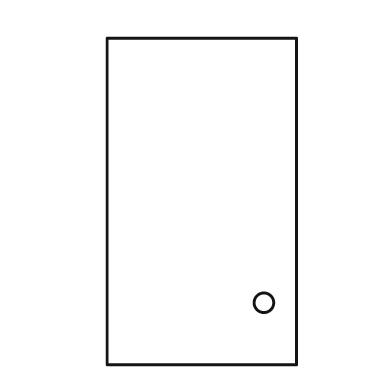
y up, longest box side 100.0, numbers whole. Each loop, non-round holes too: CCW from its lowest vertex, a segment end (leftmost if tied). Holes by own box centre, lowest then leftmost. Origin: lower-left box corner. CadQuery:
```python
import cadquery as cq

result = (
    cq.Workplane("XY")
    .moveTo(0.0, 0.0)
    .lineTo(58.0, 0.0)
    .lineTo(58.0, 100.0)
    .lineTo(0.0, 100.0)
    .close()
    .moveTo(48.0, 19.0)
    .circle(3.0)
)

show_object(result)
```